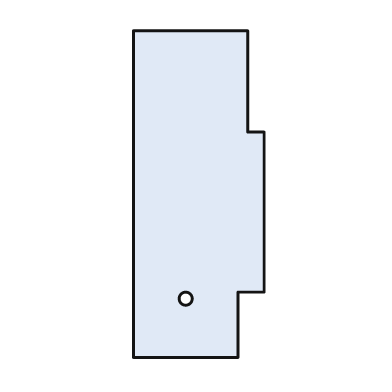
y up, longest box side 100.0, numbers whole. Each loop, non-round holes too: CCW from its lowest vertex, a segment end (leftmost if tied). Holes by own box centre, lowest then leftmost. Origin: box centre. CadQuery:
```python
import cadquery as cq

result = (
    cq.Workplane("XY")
    .moveTo(-20.0, -50.0)
    .lineTo(12.0, -50.0)
    .lineTo(12.0, -30.0)
    .lineTo(20.0, -30.0)
    .lineTo(20.0, 19.0)
    .lineTo(15.0, 19.0)
    .lineTo(15.0, 50.0)
    .lineTo(-20.0, 50.0)
    .close()
    .moveTo(-4.0, -32.0)
    .circle(2.0)
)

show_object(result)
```